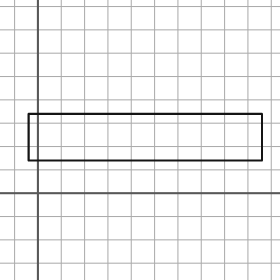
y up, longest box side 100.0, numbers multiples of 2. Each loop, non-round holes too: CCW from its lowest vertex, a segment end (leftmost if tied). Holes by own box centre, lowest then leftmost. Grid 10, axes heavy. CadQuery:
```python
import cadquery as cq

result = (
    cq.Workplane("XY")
    .moveTo(-4.0, 14.0)
    .lineTo(96.0, 14.0)
    .lineTo(96.0, 34.0)
    .lineTo(-4.0, 34.0)
    .close()
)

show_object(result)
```